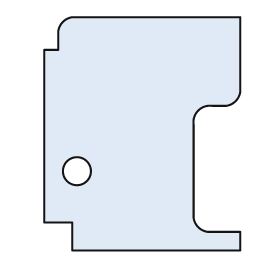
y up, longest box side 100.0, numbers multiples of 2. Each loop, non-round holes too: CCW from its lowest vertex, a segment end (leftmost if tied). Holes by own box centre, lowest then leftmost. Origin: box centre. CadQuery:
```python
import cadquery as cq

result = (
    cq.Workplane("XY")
    .moveTo(-30.0, -50.0)
    .lineTo(42.0, -50.0)
    .lineTo(42.0, -42.0)
    .lineTo(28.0, -42.0)
    .threePointArc((24.0, -40.0), (22.0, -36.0))
    .lineTo(22.0, 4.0)
    .threePointArc((24.0, 10.0), (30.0, 12.0))
    .lineTo(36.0, 12.0)
    .threePointArc((40.0, 14.0), (42.0, 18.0))
    .lineTo(42.0, 50.0)
    .lineTo(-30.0, 50.0)
    .threePointArc((-34.0, 48.0), (-36.0, 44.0))
    .lineTo(-36.0, 36.0)
    .lineTo(-42.0, 36.0)
    .lineTo(-42.0, -38.0)
    .lineTo(-30.0, -38.0)
    .close()
    .moveTo(-28.0, -16.0)
    .circle(6.0)
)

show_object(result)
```